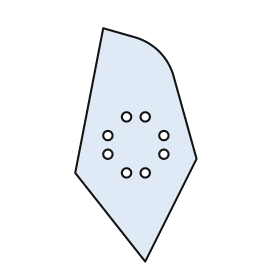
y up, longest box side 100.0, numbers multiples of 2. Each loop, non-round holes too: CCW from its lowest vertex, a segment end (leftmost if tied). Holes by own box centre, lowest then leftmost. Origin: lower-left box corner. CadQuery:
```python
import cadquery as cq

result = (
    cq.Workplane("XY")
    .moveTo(30.0, 0.0)
    .lineTo(52.0, 44.0)
    .lineTo(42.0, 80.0)
    .threePointArc((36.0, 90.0), (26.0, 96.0))
    .lineTo(12.0, 100.0)
    .lineTo(0.0, 38.0)
    .close()
    .moveTo(22.0, 38.0)
    .circle(2.0)
    .moveTo(30.0, 38.0)
    .circle(2.0)
    .moveTo(14.0, 46.0)
    .circle(2.0)
    .moveTo(38.0, 46.0)
    .circle(2.0)
    .moveTo(14.0, 54.0)
    .circle(2.0)
    .moveTo(38.0, 54.0)
    .circle(2.0)
    .moveTo(22.0, 62.0)
    .circle(2.0)
    .moveTo(30.0, 62.0)
    .circle(2.0)
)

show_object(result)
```